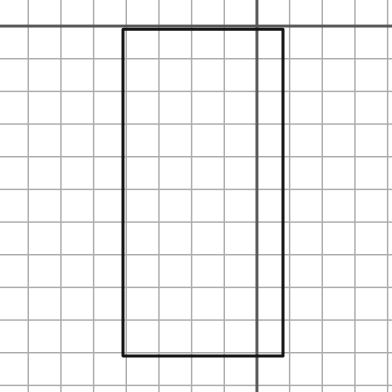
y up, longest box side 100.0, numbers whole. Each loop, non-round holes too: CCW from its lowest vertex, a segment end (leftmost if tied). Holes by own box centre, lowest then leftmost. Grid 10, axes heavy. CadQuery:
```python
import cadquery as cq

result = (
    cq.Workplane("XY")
    .moveTo(-41.0, -101.0)
    .lineTo(8.0, -101.0)
    .lineTo(8.0, -1.0)
    .lineTo(-41.0, -1.0)
    .close()
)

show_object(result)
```